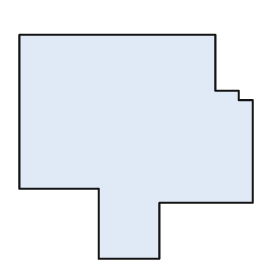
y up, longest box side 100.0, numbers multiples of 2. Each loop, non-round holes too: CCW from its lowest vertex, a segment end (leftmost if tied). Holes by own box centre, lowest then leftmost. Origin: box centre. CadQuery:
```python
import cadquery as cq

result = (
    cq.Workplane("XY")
    .moveTo(-16.0, -48.0)
    .lineTo(10.0, -48.0)
    .lineTo(10.0, -24.0)
    .lineTo(50.0, -24.0)
    .lineTo(50.0, 20.0)
    .lineTo(44.0, 20.0)
    .lineTo(44.0, 24.0)
    .lineTo(34.0, 24.0)
    .lineTo(34.0, 48.0)
    .lineTo(-50.0, 48.0)
    .lineTo(-50.0, -18.0)
    .lineTo(-16.0, -18.0)
    .close()
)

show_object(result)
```